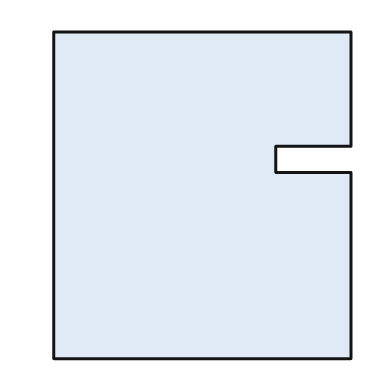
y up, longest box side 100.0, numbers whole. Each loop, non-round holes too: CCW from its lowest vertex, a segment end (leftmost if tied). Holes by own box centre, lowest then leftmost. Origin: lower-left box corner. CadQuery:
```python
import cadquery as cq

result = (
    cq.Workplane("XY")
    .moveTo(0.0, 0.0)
    .lineTo(91.0, 0.0)
    .lineTo(91.0, 57.0)
    .lineTo(68.0, 57.0)
    .lineTo(68.0, 65.0)
    .lineTo(91.0, 65.0)
    .lineTo(91.0, 100.0)
    .lineTo(0.0, 100.0)
    .close()
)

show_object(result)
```